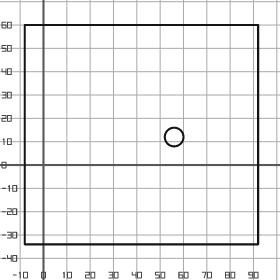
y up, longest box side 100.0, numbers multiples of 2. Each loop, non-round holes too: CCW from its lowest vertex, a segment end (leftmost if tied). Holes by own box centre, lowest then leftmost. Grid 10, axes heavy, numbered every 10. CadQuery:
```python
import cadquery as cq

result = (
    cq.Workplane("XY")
    .moveTo(-8.0, -34.0)
    .lineTo(92.0, -34.0)
    .lineTo(92.0, 60.0)
    .lineTo(-8.0, 60.0)
    .close()
    .moveTo(56.0, 12.0)
    .circle(4.0)
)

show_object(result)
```